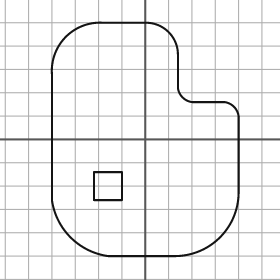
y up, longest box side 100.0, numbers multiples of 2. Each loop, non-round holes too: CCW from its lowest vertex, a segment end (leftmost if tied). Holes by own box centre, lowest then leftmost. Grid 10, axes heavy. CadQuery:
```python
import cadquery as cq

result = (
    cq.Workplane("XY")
    .moveTo(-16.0, -50.0)
    .lineTo(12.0, -50.0)
    .threePointArc((32.0, -42.0), (40.0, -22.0))
    .lineTo(40.0, 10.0)
    .threePointArc((38.0, 14.0), (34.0, 16.0))
    .lineTo(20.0, 16.0)
    .threePointArc((16.0, 18.0), (14.0, 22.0))
    .lineTo(14.0, 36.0)
    .threePointArc((10.0, 46.0), (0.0, 50.0))
    .lineTo(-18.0, 50.0)
    .threePointArc((-34.0, 44.0), (-40.0, 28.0))
    .lineTo(-40.0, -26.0)
    .threePointArc((-32.0, -42.0), (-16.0, -50.0))
    .close()
    .moveTo(-22.0, -26.0)
    .lineTo(-10.0, -26.0)
    .lineTo(-10.0, -14.0)
    .lineTo(-22.0, -14.0)
    .close()
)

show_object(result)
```